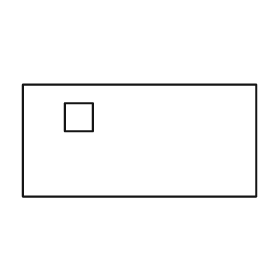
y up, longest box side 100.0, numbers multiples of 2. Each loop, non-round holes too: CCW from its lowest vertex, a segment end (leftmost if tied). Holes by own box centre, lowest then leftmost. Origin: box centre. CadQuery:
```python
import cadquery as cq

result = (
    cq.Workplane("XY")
    .moveTo(-50.0, -24.0)
    .lineTo(50.0, -24.0)
    .lineTo(50.0, 24.0)
    .lineTo(-50.0, 24.0)
    .close()
    .moveTo(-32.0, 4.0)
    .lineTo(-20.0, 4.0)
    .lineTo(-20.0, 16.0)
    .lineTo(-32.0, 16.0)
    .close()
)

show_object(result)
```